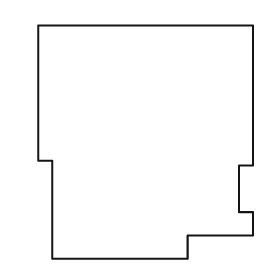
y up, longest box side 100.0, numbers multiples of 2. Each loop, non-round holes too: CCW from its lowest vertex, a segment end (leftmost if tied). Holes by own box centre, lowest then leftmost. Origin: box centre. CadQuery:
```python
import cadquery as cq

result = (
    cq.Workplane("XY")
    .moveTo(-40.0, -50.0)
    .lineTo(18.0, -50.0)
    .lineTo(18.0, -40.0)
    .lineTo(46.0, -40.0)
    .lineTo(46.0, -30.0)
    .lineTo(40.0, -30.0)
    .lineTo(40.0, -10.0)
    .lineTo(46.0, -10.0)
    .lineTo(46.0, 50.0)
    .lineTo(-46.0, 50.0)
    .lineTo(-46.0, -8.0)
    .lineTo(-40.0, -8.0)
    .close()
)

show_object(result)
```